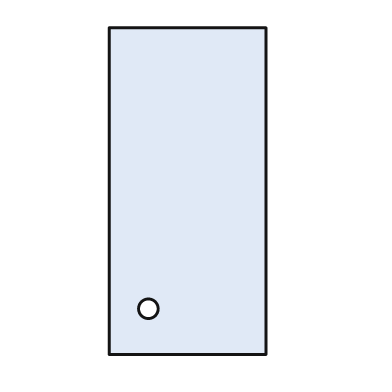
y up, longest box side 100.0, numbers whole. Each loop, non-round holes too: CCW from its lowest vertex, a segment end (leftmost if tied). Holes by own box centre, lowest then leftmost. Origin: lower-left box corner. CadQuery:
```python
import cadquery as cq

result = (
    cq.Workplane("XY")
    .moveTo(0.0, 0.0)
    .lineTo(48.0, 0.0)
    .lineTo(48.0, 100.0)
    .lineTo(0.0, 100.0)
    .close()
    .moveTo(12.0, 14.0)
    .circle(3.0)
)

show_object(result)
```